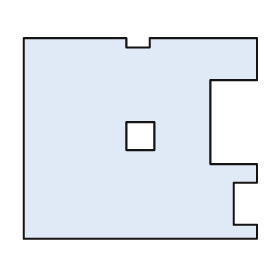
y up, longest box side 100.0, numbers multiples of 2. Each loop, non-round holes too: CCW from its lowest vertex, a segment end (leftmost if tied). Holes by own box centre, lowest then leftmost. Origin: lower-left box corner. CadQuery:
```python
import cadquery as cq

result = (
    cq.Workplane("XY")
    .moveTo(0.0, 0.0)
    .lineTo(100.0, 0.0)
    .lineTo(100.0, 6.0)
    .lineTo(90.0, 6.0)
    .lineTo(90.0, 24.0)
    .lineTo(100.0, 24.0)
    .lineTo(100.0, 32.0)
    .lineTo(80.0, 32.0)
    .lineTo(80.0, 68.0)
    .lineTo(100.0, 68.0)
    .lineTo(100.0, 86.0)
    .lineTo(54.0, 86.0)
    .lineTo(54.0, 82.0)
    .lineTo(44.0, 82.0)
    .lineTo(44.0, 86.0)
    .lineTo(0.0, 86.0)
    .close()
    .moveTo(44.0, 38.0)
    .lineTo(56.0, 38.0)
    .lineTo(56.0, 50.0)
    .lineTo(44.0, 50.0)
    .close()
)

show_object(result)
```